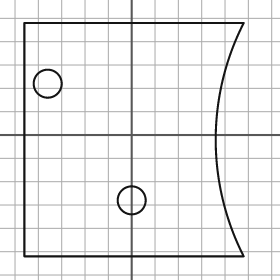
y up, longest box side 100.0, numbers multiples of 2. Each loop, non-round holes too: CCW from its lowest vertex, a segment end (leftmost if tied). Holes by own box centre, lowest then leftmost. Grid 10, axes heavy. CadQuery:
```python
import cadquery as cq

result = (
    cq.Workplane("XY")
    .moveTo(-46.0, -52.0)
    .lineTo(48.0, -52.0)
    .threePointArc((36.0, -2.0), (48.0, 48.0))
    .lineTo(-46.0, 48.0)
    .close()
    .moveTo(0.0, -28.0)
    .circle(6.0)
    .moveTo(-36.0, 22.0)
    .circle(6.0)
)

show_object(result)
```